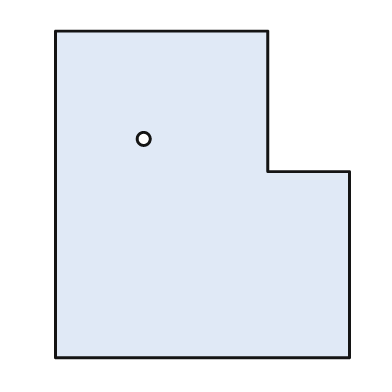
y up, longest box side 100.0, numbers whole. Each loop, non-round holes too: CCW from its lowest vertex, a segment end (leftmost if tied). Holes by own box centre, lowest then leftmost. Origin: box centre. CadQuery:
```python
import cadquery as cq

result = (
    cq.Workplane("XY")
    .moveTo(-45.0, -50.0)
    .lineTo(45.0, -50.0)
    .lineTo(45.0, 7.0)
    .lineTo(20.0, 7.0)
    .lineTo(20.0, 50.0)
    .lineTo(-45.0, 50.0)
    .close()
    .moveTo(-18.0, 17.0)
    .circle(2.0)
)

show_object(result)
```